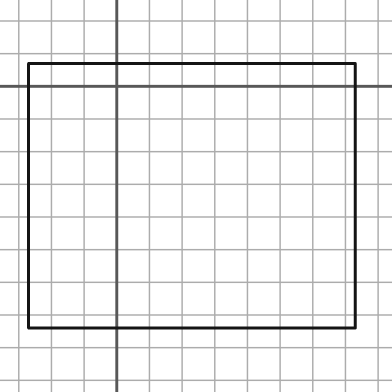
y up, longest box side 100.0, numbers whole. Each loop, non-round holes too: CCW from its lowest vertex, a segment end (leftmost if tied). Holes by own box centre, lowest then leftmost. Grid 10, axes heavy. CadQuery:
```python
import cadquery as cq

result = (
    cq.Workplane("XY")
    .moveTo(-27.0, -74.0)
    .lineTo(73.0, -74.0)
    .lineTo(73.0, 7.0)
    .lineTo(-27.0, 7.0)
    .close()
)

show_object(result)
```